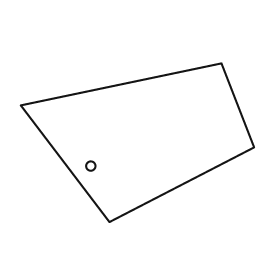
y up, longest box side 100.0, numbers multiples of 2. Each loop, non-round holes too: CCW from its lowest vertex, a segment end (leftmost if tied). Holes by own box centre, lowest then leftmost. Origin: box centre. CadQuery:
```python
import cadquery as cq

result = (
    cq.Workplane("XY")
    .moveTo(-12.0, -34.0)
    .lineTo(50.0, -2.0)
    .lineTo(36.0, 34.0)
    .lineTo(-50.0, 16.0)
    .close()
    .moveTo(-20.0, -10.0)
    .circle(2.0)
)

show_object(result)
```